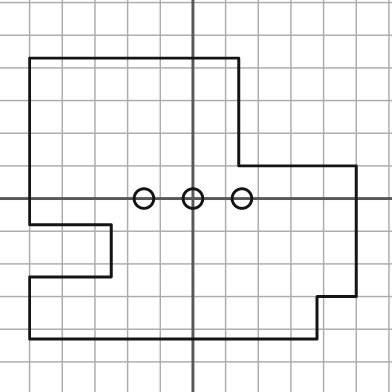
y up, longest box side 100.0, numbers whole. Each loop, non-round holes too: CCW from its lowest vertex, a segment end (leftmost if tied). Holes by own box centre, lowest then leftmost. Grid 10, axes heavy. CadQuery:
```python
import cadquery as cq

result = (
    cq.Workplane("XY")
    .moveTo(-50.0, -43.0)
    .lineTo(38.0, -43.0)
    .lineTo(38.0, -30.0)
    .lineTo(50.0, -30.0)
    .lineTo(50.0, 10.0)
    .lineTo(14.0, 10.0)
    .lineTo(14.0, 43.0)
    .lineTo(-50.0, 43.0)
    .lineTo(-50.0, -8.0)
    .lineTo(-25.0, -8.0)
    .lineTo(-25.0, -24.0)
    .lineTo(-50.0, -24.0)
    .close()
    .moveTo(-15.0, 0.0)
    .circle(3.0)
    .moveTo(0.0, 0.0)
    .circle(3.0)
    .moveTo(15.0, 0.0)
    .circle(3.0)
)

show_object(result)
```